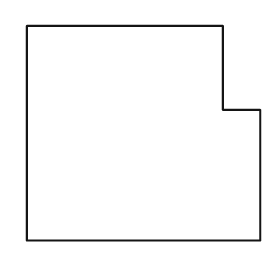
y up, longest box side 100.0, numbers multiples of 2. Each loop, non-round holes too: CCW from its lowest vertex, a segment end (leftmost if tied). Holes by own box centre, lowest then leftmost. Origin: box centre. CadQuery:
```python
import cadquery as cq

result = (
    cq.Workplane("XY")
    .moveTo(-50.0, -46.0)
    .lineTo(50.0, -46.0)
    .lineTo(50.0, 10.0)
    .lineTo(34.0, 10.0)
    .lineTo(34.0, 46.0)
    .lineTo(-50.0, 46.0)
    .close()
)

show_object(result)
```